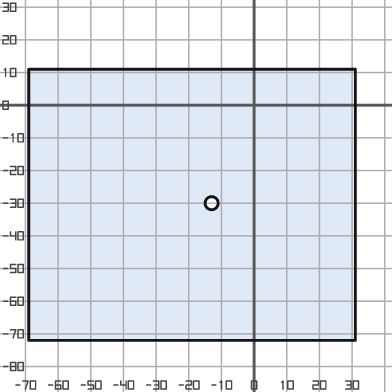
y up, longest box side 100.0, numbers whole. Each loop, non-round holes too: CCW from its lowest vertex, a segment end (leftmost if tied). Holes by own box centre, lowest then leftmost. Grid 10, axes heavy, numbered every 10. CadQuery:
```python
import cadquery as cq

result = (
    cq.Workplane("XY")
    .moveTo(-69.0, -72.0)
    .lineTo(31.0, -72.0)
    .lineTo(31.0, 11.0)
    .lineTo(-69.0, 11.0)
    .close()
    .moveTo(-13.0, -30.0)
    .circle(2.0)
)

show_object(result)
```